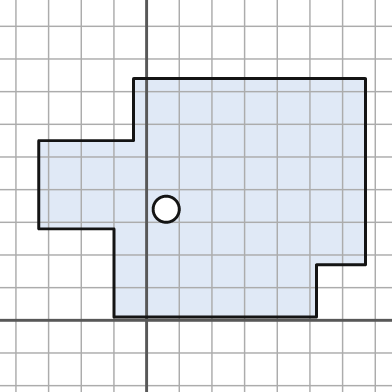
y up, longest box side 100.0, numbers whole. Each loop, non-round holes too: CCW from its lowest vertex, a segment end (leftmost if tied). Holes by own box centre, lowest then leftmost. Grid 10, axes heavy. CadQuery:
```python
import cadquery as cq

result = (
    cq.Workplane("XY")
    .moveTo(-10.0, 1.0)
    .lineTo(52.0, 1.0)
    .lineTo(52.0, 17.0)
    .lineTo(67.0, 17.0)
    .lineTo(67.0, 74.0)
    .lineTo(-4.0, 74.0)
    .lineTo(-4.0, 55.0)
    .lineTo(-33.0, 55.0)
    .lineTo(-33.0, 28.0)
    .lineTo(-10.0, 28.0)
    .close()
    .moveTo(6.0, 34.0)
    .circle(4.0)
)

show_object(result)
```